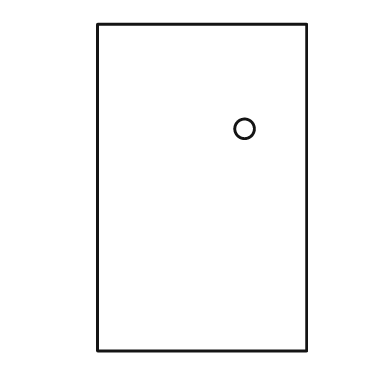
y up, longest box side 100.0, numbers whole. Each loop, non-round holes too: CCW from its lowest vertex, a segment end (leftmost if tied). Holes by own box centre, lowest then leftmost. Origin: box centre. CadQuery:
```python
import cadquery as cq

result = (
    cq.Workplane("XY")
    .moveTo(-32.0, -50.0)
    .lineTo(32.0, -50.0)
    .lineTo(32.0, 50.0)
    .lineTo(-32.0, 50.0)
    .close()
    .moveTo(13.0, 18.0)
    .circle(3.0)
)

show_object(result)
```